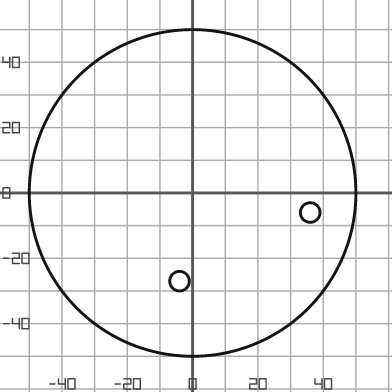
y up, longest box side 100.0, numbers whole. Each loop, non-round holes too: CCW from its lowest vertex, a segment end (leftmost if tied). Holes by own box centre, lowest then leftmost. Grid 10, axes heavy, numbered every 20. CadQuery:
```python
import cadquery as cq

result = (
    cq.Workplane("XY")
    .moveTo(0.0, 0.0)
    .circle(50.0)
    .moveTo(-4.0, -27.0)
    .circle(3.0)
    .moveTo(36.0, -6.0)
    .circle(3.0)
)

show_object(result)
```